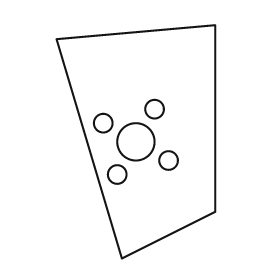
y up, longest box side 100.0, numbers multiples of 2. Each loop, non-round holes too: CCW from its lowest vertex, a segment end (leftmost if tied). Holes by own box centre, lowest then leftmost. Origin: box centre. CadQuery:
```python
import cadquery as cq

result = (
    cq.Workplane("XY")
    .moveTo(-6.0, -50.0)
    .lineTo(34.0, -30.0)
    .lineTo(34.0, 50.0)
    .lineTo(-34.0, 44.0)
    .close()
    .moveTo(-8.0, -14.0)
    .circle(4.0)
    .moveTo(14.0, -8.0)
    .circle(4.0)
    .moveTo(0.0, 0.0)
    .circle(8.0)
    .moveTo(-14.0, 8.0)
    .circle(4.0)
    .moveTo(8.0, 14.0)
    .circle(4.0)
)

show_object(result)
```